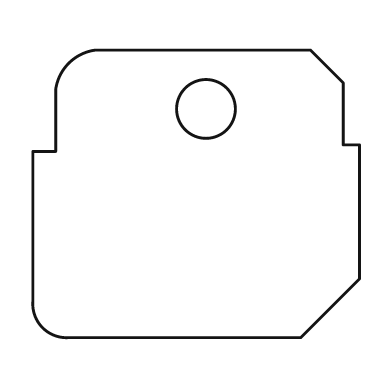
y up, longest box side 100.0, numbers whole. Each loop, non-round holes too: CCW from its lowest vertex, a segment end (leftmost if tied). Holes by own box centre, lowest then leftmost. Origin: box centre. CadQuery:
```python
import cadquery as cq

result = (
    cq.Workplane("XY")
    .moveTo(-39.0, -44.0)
    .lineTo(32.0, -44.0)
    .lineTo(50.0, -26.0)
    .lineTo(50.0, 15.0)
    .lineTo(45.0, 15.0)
    .lineTo(45.0, 34.0)
    .lineTo(35.0, 44.0)
    .lineTo(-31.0, 44.0)
    .threePointArc((-39.0, 40.0), (-43.0, 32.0))
    .lineTo(-43.0, 13.0)
    .lineTo(-50.0, 13.0)
    .lineTo(-50.0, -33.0)
    .threePointArc((-47.0, -41.0), (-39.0, -44.0))
    .close()
    .moveTo(3.0, 26.0)
    .circle(9.0)
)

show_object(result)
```